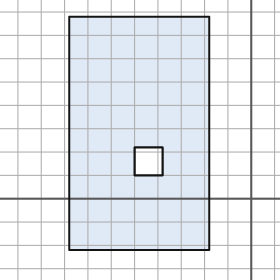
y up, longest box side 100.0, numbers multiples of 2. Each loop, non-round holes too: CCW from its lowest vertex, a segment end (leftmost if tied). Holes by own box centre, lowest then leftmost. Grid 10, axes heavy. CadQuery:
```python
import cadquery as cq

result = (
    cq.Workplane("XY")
    .moveTo(-78.0, -22.0)
    .lineTo(-18.0, -22.0)
    .lineTo(-18.0, 78.0)
    .lineTo(-78.0, 78.0)
    .close()
    .moveTo(-50.0, 10.0)
    .lineTo(-38.0, 10.0)
    .lineTo(-38.0, 22.0)
    .lineTo(-50.0, 22.0)
    .close()
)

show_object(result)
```